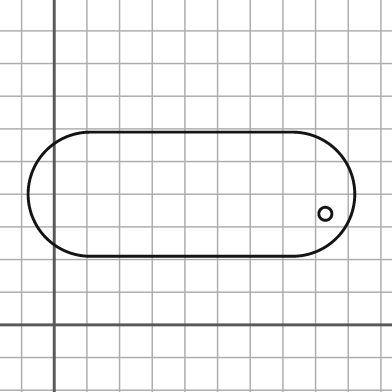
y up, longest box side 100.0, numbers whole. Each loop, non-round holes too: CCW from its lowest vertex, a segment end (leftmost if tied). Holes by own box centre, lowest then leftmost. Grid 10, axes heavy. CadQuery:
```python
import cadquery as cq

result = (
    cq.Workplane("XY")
    .moveTo(11.0, 21.0)
    .lineTo(73.0, 21.0)
    .threePointArc((92.0, 40.0), (73.0, 59.0))
    .lineTo(11.0, 59.0)
    .threePointArc((-8.0, 40.0), (11.0, 21.0))
    .close()
    .moveTo(83.0, 34.0)
    .circle(2.0)
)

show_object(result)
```